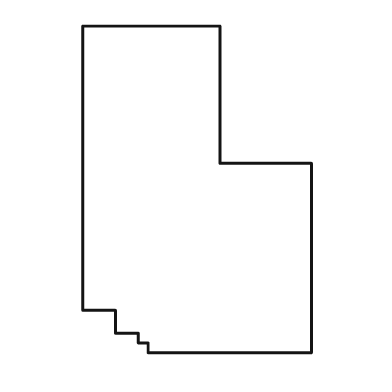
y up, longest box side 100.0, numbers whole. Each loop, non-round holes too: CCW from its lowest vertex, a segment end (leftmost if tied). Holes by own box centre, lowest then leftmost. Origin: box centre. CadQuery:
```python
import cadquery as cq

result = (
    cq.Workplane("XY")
    .moveTo(-15.0, -50.0)
    .lineTo(35.0, -50.0)
    .lineTo(35.0, 8.0)
    .lineTo(7.0, 8.0)
    .lineTo(7.0, 50.0)
    .lineTo(-35.0, 50.0)
    .lineTo(-35.0, -37.0)
    .lineTo(-25.0, -37.0)
    .lineTo(-25.0, -44.0)
    .lineTo(-18.0, -44.0)
    .lineTo(-18.0, -47.0)
    .lineTo(-15.0, -47.0)
    .close()
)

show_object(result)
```